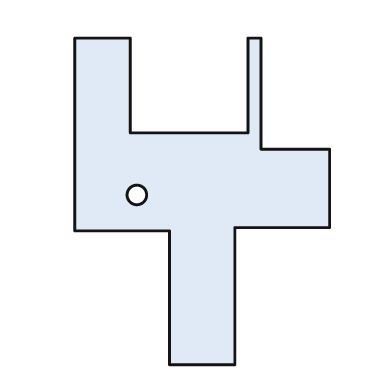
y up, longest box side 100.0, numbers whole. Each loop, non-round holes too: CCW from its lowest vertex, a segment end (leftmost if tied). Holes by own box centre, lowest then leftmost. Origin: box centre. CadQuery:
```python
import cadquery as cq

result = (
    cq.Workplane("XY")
    .moveTo(-10.0, -50.0)
    .lineTo(10.0, -50.0)
    .lineTo(10.0, -8.0)
    .lineTo(39.0, -8.0)
    .lineTo(39.0, 16.0)
    .lineTo(18.0, 16.0)
    .lineTo(18.0, 50.0)
    .lineTo(14.0, 50.0)
    .lineTo(14.0, 21.0)
    .lineTo(-22.0, 21.0)
    .lineTo(-22.0, 50.0)
    .lineTo(-39.0, 50.0)
    .lineTo(-39.0, -9.0)
    .lineTo(-10.0, -9.0)
    .close()
    .moveTo(-20.0, 2.0)
    .circle(3.0)
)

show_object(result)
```